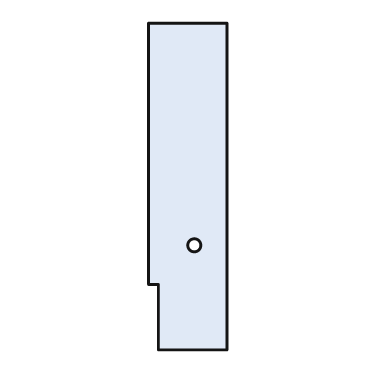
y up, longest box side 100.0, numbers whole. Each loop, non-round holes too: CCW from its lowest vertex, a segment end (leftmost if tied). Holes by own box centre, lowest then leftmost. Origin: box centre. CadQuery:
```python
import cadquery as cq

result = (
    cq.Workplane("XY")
    .moveTo(-9.0, -50.0)
    .lineTo(12.0, -50.0)
    .lineTo(12.0, 50.0)
    .lineTo(-12.0, 50.0)
    .lineTo(-12.0, -30.0)
    .lineTo(-9.0, -30.0)
    .close()
    .moveTo(2.0, -18.0)
    .circle(2.0)
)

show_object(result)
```